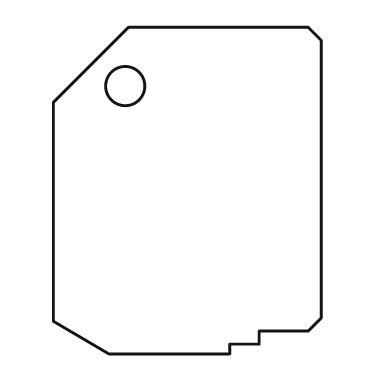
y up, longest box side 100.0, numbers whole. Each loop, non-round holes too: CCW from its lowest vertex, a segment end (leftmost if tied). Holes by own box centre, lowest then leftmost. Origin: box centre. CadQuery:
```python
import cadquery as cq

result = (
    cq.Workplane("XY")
    .moveTo(-24.0, -50.0)
    .lineTo(13.0, -50.0)
    .lineTo(13.0, -47.0)
    .lineTo(22.0, -47.0)
    .lineTo(22.0, -43.0)
    .lineTo(37.0, -43.0)
    .lineTo(41.0, -39.0)
    .lineTo(41.0, 46.0)
    .lineTo(37.0, 50.0)
    .lineTo(-18.0, 50.0)
    .lineTo(-41.0, 27.0)
    .lineTo(-41.0, -40.0)
    .close()
    .moveTo(-19.0, 32.0)
    .circle(6.0)
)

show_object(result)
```